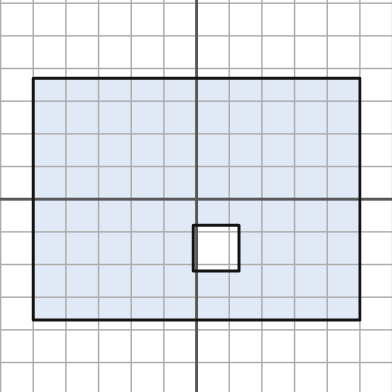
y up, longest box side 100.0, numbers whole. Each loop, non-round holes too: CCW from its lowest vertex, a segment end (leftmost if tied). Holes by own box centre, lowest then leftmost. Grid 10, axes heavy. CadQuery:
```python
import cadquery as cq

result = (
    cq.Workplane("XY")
    .moveTo(-50.0, -37.0)
    .lineTo(50.0, -37.0)
    .lineTo(50.0, 37.0)
    .lineTo(-50.0, 37.0)
    .close()
    .moveTo(-1.0, -22.0)
    .lineTo(13.0, -22.0)
    .lineTo(13.0, -8.0)
    .lineTo(-1.0, -8.0)
    .close()
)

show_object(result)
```